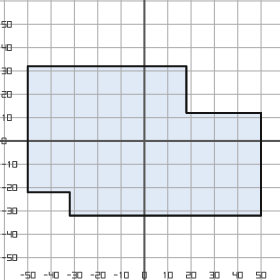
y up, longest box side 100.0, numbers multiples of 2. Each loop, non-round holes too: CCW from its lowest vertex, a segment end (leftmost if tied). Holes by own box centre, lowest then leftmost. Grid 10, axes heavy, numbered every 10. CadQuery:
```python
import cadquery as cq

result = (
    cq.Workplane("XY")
    .moveTo(-32.0, -32.0)
    .lineTo(50.0, -32.0)
    .lineTo(50.0, 12.0)
    .lineTo(18.0, 12.0)
    .lineTo(18.0, 32.0)
    .lineTo(-50.0, 32.0)
    .lineTo(-50.0, -22.0)
    .lineTo(-32.0, -22.0)
    .close()
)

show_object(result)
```